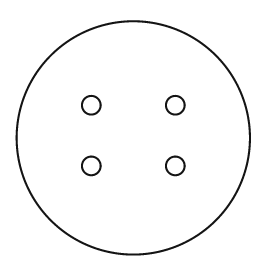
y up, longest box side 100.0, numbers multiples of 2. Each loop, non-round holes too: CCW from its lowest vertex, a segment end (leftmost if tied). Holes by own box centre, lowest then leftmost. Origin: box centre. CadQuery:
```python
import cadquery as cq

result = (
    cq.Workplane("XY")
    .moveTo(0.0, 0.0)
    .circle(50.0)
    .moveTo(-18.0, -12.0)
    .circle(4.0)
    .moveTo(18.0, -12.0)
    .circle(4.0)
    .moveTo(-18.0, 14.0)
    .circle(4.0)
    .moveTo(18.0, 14.0)
    .circle(4.0)
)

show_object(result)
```